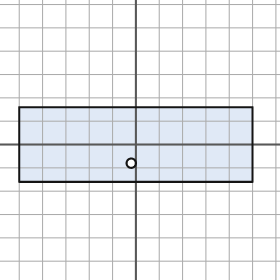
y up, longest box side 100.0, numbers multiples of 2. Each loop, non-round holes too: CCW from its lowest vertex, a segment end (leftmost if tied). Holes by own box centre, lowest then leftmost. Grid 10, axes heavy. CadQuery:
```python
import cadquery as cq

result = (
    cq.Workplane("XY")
    .moveTo(-50.0, -16.0)
    .lineTo(50.0, -16.0)
    .lineTo(50.0, 16.0)
    .lineTo(-50.0, 16.0)
    .close()
    .moveTo(-2.0, -8.0)
    .circle(2.0)
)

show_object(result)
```